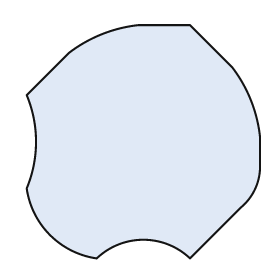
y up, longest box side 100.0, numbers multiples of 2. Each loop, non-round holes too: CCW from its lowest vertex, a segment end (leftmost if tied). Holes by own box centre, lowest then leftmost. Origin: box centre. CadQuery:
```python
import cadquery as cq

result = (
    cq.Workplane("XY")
    .moveTo(-20.0, -50.0)
    .threePointArc((0.0, -42.0), (20.0, -50.0))
    .lineTo(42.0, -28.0)
    .threePointArc((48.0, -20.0), (50.0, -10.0))
    .lineTo(50.0, 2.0)
    .threePointArc((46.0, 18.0), (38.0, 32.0))
    .lineTo(20.0, 50.0)
    .lineTo(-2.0, 50.0)
    .threePointArc((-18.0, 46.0), (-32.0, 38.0))
    .lineTo(-50.0, 20.0)
    .threePointArc((-46.0, 0.0), (-50.0, -20.0))
    .threePointArc((-40.0, -40.0), (-20.0, -50.0))
    .close()
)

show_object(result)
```